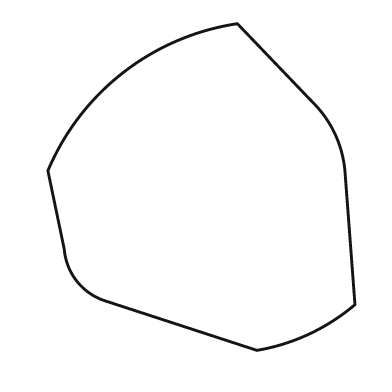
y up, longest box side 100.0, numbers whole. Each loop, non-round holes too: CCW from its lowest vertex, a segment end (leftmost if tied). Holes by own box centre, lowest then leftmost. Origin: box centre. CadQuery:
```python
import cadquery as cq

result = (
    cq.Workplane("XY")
    .moveTo(17.0, -50.0)
    .threePointArc((33.0, -45.0), (47.0, -36.0))
    .lineTo(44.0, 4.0)
    .threePointArc((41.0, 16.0), (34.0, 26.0))
    .lineTo(11.0, 50.0)
    .threePointArc((-24.0, 35.0), (-47.0, 5.0))
    .lineTo(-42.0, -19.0)
    .threePointArc((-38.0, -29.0), (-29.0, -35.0))
    .close()
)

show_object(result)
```